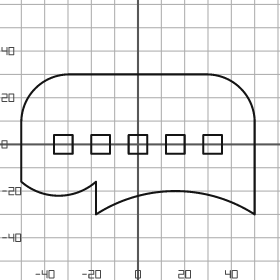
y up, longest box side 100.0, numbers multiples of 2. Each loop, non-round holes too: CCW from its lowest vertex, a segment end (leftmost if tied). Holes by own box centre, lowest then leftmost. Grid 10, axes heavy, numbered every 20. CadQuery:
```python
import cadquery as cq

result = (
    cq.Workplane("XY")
    .moveTo(-18.0, -30.0)
    .threePointArc((16.0, -20.0), (50.0, -30.0))
    .lineTo(50.0, 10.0)
    .threePointArc((44.0, 24.0), (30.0, 30.0))
    .lineTo(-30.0, 30.0)
    .threePointArc((-44.0, 24.0), (-50.0, 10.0))
    .lineTo(-50.0, -16.0)
    .threePointArc((-34.0, -22.0), (-18.0, -16.0))
    .close()
    .moveTo(-36.0, -4.0)
    .lineTo(-28.0, -4.0)
    .lineTo(-28.0, 4.0)
    .lineTo(-36.0, 4.0)
    .close()
    .moveTo(-20.0, -4.0)
    .lineTo(-12.0, -4.0)
    .lineTo(-12.0, 4.0)
    .lineTo(-20.0, 4.0)
    .close()
    .moveTo(-4.0, -4.0)
    .lineTo(4.0, -4.0)
    .lineTo(4.0, 4.0)
    .lineTo(-4.0, 4.0)
    .close()
    .moveTo(12.0, -4.0)
    .lineTo(20.0, -4.0)
    .lineTo(20.0, 4.0)
    .lineTo(12.0, 4.0)
    .close()
    .moveTo(28.0, -4.0)
    .lineTo(36.0, -4.0)
    .lineTo(36.0, 4.0)
    .lineTo(28.0, 4.0)
    .close()
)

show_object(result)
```